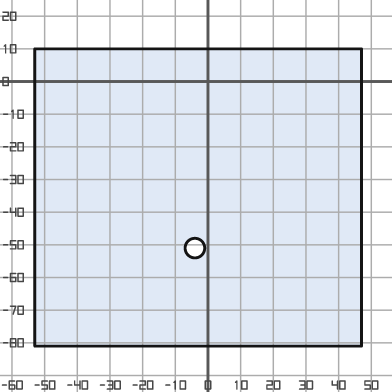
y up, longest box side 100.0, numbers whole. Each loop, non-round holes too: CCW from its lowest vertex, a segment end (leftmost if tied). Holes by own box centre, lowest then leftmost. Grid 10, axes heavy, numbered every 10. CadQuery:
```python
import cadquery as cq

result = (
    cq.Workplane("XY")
    .moveTo(-53.0, -81.0)
    .lineTo(47.0, -81.0)
    .lineTo(47.0, 10.0)
    .lineTo(-53.0, 10.0)
    .close()
    .moveTo(-4.0, -51.0)
    .circle(3.0)
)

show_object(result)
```